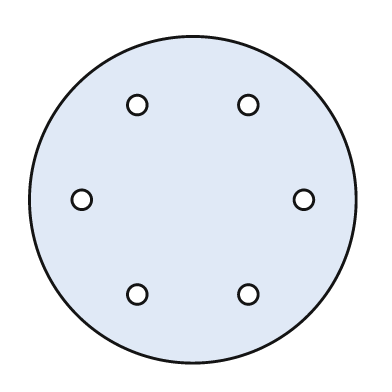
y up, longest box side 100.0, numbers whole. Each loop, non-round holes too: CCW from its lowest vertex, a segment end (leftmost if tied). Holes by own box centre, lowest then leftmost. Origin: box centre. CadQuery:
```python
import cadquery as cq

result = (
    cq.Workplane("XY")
    .moveTo(0.0, 0.0)
    .circle(50.0)
    .moveTo(-17.0, -29.0)
    .circle(3.0)
    .moveTo(17.0, -29.0)
    .circle(3.0)
    .moveTo(-34.0, 0.0)
    .circle(3.0)
    .moveTo(34.0, 0.0)
    .circle(3.0)
    .moveTo(-17.0, 29.0)
    .circle(3.0)
    .moveTo(17.0, 29.0)
    .circle(3.0)
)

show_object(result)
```